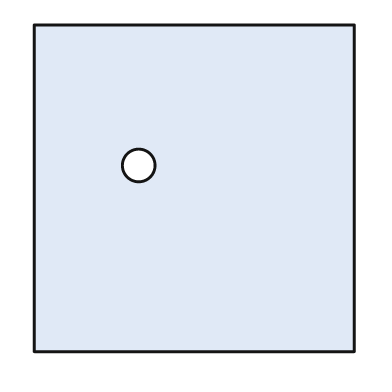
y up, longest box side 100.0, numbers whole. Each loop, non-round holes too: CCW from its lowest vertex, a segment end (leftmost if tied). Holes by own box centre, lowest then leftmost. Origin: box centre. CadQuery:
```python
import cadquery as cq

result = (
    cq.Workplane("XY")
    .moveTo(-49.0, -50.0)
    .lineTo(49.0, -50.0)
    .lineTo(49.0, 50.0)
    .lineTo(-49.0, 50.0)
    .close()
    .moveTo(-17.0, 7.0)
    .circle(5.0)
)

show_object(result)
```